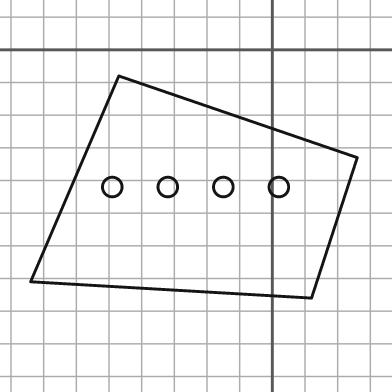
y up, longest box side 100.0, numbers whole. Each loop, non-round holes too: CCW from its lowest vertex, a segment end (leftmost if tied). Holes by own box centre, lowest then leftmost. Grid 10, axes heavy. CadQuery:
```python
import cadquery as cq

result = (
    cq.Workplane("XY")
    .moveTo(12.0, -76.0)
    .lineTo(26.0, -33.0)
    .lineTo(-47.0, -8.0)
    .lineTo(-74.0, -71.0)
    .close()
    .moveTo(-49.0, -42.0)
    .circle(3.0)
    .moveTo(-32.0, -42.0)
    .circle(3.0)
    .moveTo(-15.0, -42.0)
    .circle(3.0)
    .moveTo(2.0, -42.0)
    .circle(3.0)
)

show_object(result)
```